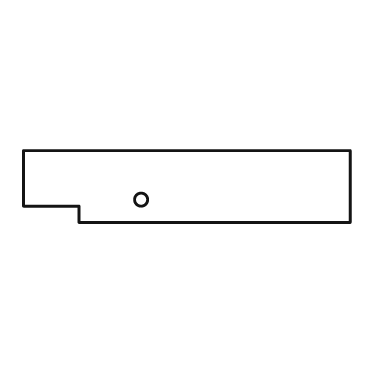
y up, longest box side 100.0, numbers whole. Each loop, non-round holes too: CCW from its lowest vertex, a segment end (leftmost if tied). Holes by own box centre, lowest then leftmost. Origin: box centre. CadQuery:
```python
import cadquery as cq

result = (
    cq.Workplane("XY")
    .moveTo(-33.0, -11.0)
    .lineTo(50.0, -11.0)
    .lineTo(50.0, 11.0)
    .lineTo(-50.0, 11.0)
    .lineTo(-50.0, -6.0)
    .lineTo(-33.0, -6.0)
    .close()
    .moveTo(-14.0, -4.0)
    .circle(2.0)
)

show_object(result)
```